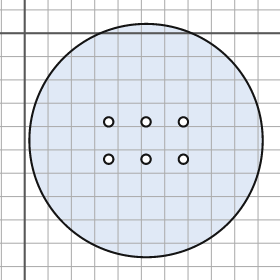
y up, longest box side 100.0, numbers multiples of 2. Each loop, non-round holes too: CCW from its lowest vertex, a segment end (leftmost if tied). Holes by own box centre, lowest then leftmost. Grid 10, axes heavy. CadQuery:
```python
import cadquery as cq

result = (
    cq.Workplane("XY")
    .moveTo(52.0, -46.0)
    .circle(50.0)
    .moveTo(36.0, -54.0)
    .circle(2.0)
    .moveTo(52.0, -54.0)
    .circle(2.0)
    .moveTo(68.0, -54.0)
    .circle(2.0)
    .moveTo(36.0, -38.0)
    .circle(2.0)
    .moveTo(52.0, -38.0)
    .circle(2.0)
    .moveTo(68.0, -38.0)
    .circle(2.0)
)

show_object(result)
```